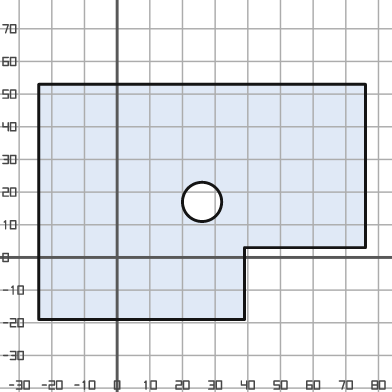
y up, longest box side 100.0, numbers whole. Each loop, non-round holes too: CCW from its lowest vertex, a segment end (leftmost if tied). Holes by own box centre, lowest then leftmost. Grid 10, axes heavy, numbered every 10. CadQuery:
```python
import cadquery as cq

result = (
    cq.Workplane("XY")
    .moveTo(-24.0, -19.0)
    .lineTo(39.0, -19.0)
    .lineTo(39.0, 3.0)
    .lineTo(76.0, 3.0)
    .lineTo(76.0, 53.0)
    .lineTo(-24.0, 53.0)
    .close()
    .moveTo(26.0, 17.0)
    .circle(6.0)
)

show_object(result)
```